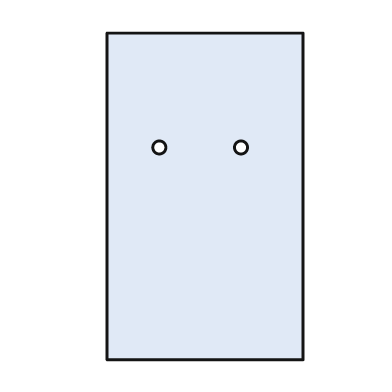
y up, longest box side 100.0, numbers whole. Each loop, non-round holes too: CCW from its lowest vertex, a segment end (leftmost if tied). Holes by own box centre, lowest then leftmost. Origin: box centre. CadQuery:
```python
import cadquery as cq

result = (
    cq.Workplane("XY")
    .moveTo(-30.0, -50.0)
    .lineTo(30.0, -50.0)
    .lineTo(30.0, 50.0)
    .lineTo(-30.0, 50.0)
    .close()
    .moveTo(-14.0, 15.0)
    .circle(2.0)
    .moveTo(11.0, 15.0)
    .circle(2.0)
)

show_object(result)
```